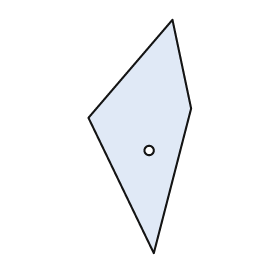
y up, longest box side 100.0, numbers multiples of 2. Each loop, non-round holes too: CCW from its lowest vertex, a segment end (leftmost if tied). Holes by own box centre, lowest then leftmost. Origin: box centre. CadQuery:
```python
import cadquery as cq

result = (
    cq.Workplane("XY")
    .moveTo(6.0, -50.0)
    .lineTo(22.0, 12.0)
    .lineTo(14.0, 50.0)
    .lineTo(-22.0, 8.0)
    .close()
    .moveTo(4.0, -6.0)
    .circle(2.0)
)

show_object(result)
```